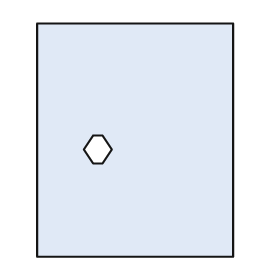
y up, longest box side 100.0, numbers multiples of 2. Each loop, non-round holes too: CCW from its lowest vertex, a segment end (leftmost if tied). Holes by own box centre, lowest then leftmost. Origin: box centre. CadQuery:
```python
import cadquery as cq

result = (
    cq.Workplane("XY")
    .moveTo(-42.0, -50.0)
    .lineTo(42.0, -50.0)
    .lineTo(42.0, 50.0)
    .lineTo(-42.0, 50.0)
    .close()
    .moveTo(-18.0, -10.0)
    .lineTo(-14.0, -10.0)
    .lineTo(-10.0, -4.0)
    .lineTo(-14.0, 2.0)
    .lineTo(-18.0, 2.0)
    .lineTo(-22.0, -4.0)
    .close()
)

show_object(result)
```